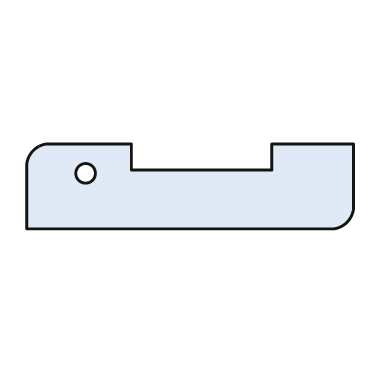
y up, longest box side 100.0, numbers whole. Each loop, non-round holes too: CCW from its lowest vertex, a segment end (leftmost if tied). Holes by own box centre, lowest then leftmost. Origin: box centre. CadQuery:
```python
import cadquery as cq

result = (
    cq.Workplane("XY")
    .moveTo(-50.0, -13.0)
    .lineTo(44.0, -13.0)
    .threePointArc((48.0, -11.0), (50.0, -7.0))
    .lineTo(50.0, 13.0)
    .lineTo(25.0, 13.0)
    .lineTo(25.0, 5.0)
    .lineTo(-18.0, 5.0)
    .lineTo(-18.0, 13.0)
    .lineTo(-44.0, 13.0)
    .threePointArc((-48.0, 11.0), (-50.0, 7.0))
    .close()
    .moveTo(-32.0, 4.0)
    .circle(3.0)
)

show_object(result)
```